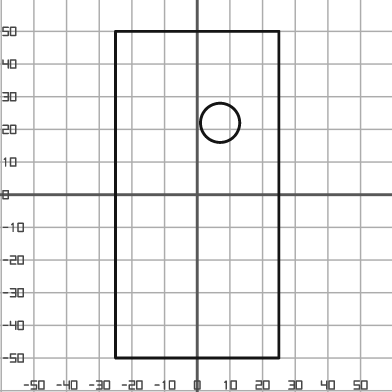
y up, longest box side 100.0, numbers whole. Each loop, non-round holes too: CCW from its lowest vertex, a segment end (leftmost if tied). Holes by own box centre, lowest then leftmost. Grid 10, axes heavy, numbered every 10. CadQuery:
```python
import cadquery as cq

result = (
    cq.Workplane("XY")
    .moveTo(-25.0, -50.0)
    .lineTo(25.0, -50.0)
    .lineTo(25.0, 50.0)
    .lineTo(-25.0, 50.0)
    .close()
    .moveTo(7.0, 22.0)
    .circle(6.0)
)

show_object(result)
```